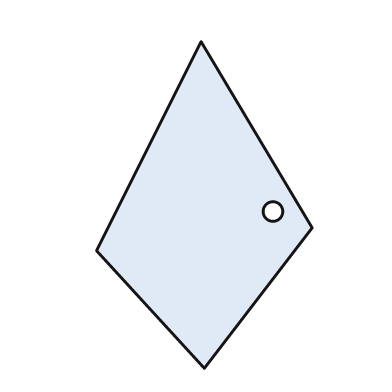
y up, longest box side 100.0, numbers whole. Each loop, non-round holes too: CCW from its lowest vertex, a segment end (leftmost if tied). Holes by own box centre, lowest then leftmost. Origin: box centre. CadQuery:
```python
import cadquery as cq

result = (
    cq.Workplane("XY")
    .moveTo(0.0, -50.0)
    .lineTo(33.0, -7.0)
    .lineTo(-1.0, 50.0)
    .lineTo(-33.0, -14.0)
    .close()
    .moveTo(21.0, -2.0)
    .circle(3.0)
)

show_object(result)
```